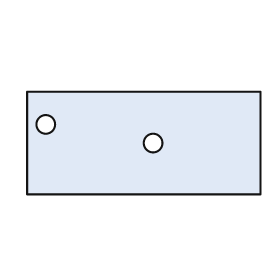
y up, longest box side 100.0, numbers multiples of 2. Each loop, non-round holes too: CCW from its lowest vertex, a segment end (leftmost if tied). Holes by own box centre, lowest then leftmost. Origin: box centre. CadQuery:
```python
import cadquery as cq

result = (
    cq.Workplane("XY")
    .moveTo(-50.0, -22.0)
    .lineTo(50.0, -22.0)
    .lineTo(50.0, 22.0)
    .lineTo(-50.0, 22.0)
    .close()
    .moveTo(4.0, 0.0)
    .circle(4.0)
    .moveTo(-42.0, 8.0)
    .circle(4.0)
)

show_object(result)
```